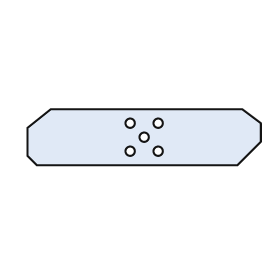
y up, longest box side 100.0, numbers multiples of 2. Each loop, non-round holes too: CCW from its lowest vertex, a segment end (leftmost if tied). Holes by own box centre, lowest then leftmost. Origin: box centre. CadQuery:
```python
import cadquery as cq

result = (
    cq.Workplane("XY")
    .moveTo(-46.0, -12.0)
    .lineTo(40.0, -12.0)
    .lineTo(50.0, -2.0)
    .lineTo(50.0, 6.0)
    .lineTo(42.0, 12.0)
    .lineTo(-40.0, 12.0)
    .lineTo(-50.0, 4.0)
    .lineTo(-50.0, -8.0)
    .close()
    .moveTo(-6.0, -6.0)
    .circle(2.0)
    .moveTo(6.0, -6.0)
    .circle(2.0)
    .moveTo(0.0, 0.0)
    .circle(2.0)
    .moveTo(-6.0, 6.0)
    .circle(2.0)
    .moveTo(6.0, 6.0)
    .circle(2.0)
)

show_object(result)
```